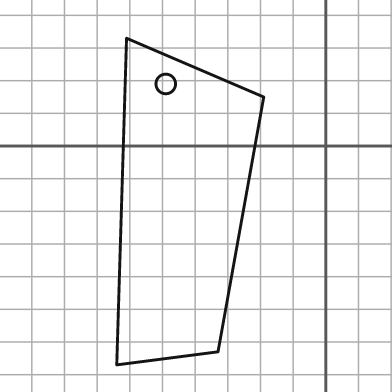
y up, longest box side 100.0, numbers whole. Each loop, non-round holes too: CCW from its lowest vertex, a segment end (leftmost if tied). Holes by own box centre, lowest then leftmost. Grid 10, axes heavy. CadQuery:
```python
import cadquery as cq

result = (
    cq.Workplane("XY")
    .moveTo(-64.0, -67.0)
    .lineTo(-33.0, -63.0)
    .lineTo(-19.0, 15.0)
    .lineTo(-61.0, 33.0)
    .close()
    .moveTo(-49.0, 19.0)
    .circle(3.0)
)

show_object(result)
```